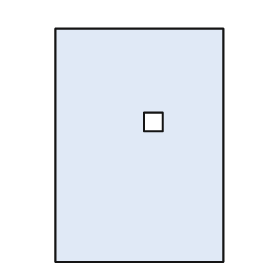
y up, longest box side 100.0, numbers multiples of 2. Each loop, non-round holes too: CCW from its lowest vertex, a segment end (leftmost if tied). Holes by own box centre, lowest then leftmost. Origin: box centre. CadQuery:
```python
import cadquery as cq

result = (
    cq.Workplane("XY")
    .moveTo(-36.0, -50.0)
    .lineTo(36.0, -50.0)
    .lineTo(36.0, 50.0)
    .lineTo(-36.0, 50.0)
    .close()
    .moveTo(2.0, 6.0)
    .lineTo(10.0, 6.0)
    .lineTo(10.0, 14.0)
    .lineTo(2.0, 14.0)
    .close()
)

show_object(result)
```